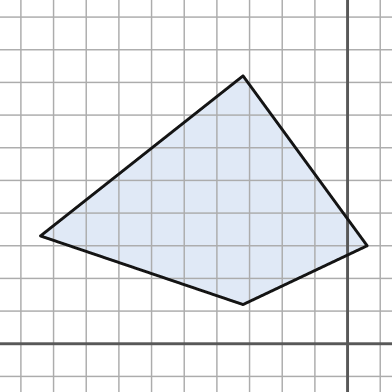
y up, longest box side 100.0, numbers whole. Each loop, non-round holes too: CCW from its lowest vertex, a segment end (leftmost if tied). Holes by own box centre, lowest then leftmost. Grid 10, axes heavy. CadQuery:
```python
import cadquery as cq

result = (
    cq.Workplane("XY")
    .moveTo(-32.0, 12.0)
    .lineTo(6.0, 30.0)
    .lineTo(-32.0, 82.0)
    .lineTo(-94.0, 33.0)
    .close()
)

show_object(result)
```